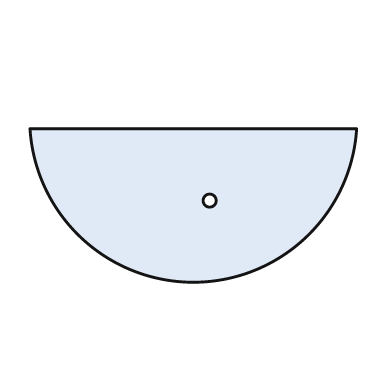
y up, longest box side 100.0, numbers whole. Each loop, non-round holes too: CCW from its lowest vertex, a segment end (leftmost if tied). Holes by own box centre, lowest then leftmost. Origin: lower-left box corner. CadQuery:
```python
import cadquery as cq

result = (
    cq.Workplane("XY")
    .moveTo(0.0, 47.0)
    .threePointArc((50.0, 0.0), (100.0, 47.0))
    .close()
    .moveTo(55.0, 25.0)
    .circle(2.0)
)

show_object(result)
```